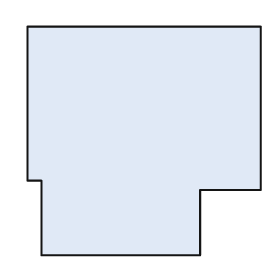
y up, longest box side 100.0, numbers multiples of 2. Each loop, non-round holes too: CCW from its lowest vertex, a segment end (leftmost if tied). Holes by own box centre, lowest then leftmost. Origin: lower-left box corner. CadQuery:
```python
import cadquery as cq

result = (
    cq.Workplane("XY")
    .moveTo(6.0, 0.0)
    .lineTo(74.0, 0.0)
    .lineTo(74.0, 28.0)
    .lineTo(100.0, 28.0)
    .lineTo(100.0, 98.0)
    .lineTo(0.0, 98.0)
    .lineTo(0.0, 32.0)
    .lineTo(6.0, 32.0)
    .close()
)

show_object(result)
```